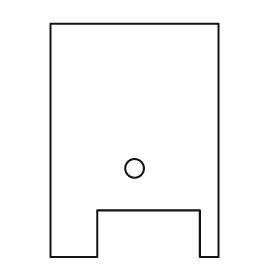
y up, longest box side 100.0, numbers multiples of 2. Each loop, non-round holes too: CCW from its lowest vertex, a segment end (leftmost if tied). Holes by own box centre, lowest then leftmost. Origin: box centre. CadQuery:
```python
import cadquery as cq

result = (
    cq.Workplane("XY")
    .moveTo(-36.0, -50.0)
    .lineTo(-16.0, -50.0)
    .lineTo(-16.0, -30.0)
    .lineTo(28.0, -30.0)
    .lineTo(28.0, -50.0)
    .lineTo(36.0, -50.0)
    .lineTo(36.0, 50.0)
    .lineTo(-36.0, 50.0)
    .close()
    .moveTo(0.0, -12.0)
    .circle(4.0)
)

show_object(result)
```